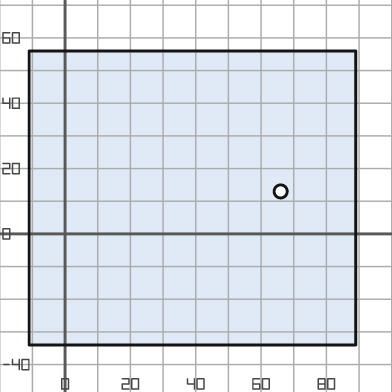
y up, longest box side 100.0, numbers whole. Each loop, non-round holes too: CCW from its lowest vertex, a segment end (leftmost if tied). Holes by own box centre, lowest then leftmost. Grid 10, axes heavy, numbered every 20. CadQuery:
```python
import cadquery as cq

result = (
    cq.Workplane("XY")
    .moveTo(-11.0, -34.0)
    .lineTo(89.0, -34.0)
    .lineTo(89.0, 56.0)
    .lineTo(-11.0, 56.0)
    .close()
    .moveTo(66.0, 13.0)
    .circle(2.0)
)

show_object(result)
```